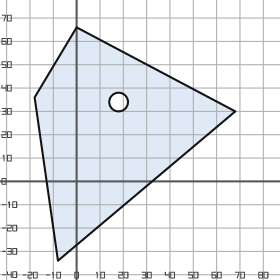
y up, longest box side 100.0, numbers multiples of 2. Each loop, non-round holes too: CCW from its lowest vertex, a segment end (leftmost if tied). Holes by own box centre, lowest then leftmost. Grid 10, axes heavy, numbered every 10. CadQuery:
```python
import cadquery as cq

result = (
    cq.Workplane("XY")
    .moveTo(-8.0, -34.0)
    .lineTo(68.0, 30.0)
    .lineTo(0.0, 66.0)
    .lineTo(-18.0, 36.0)
    .close()
    .moveTo(18.0, 34.0)
    .circle(4.0)
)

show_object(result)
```